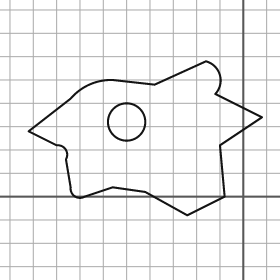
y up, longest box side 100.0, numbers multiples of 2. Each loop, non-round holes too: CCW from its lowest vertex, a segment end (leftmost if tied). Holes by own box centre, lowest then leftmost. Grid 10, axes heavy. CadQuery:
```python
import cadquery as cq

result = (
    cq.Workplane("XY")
    .moveTo(-24.0, -8.0)
    .lineTo(-8.0, 0.0)
    .lineTo(-10.0, 22.0)
    .lineTo(8.0, 34.0)
    .lineTo(-12.0, 44.0)
    .threePointArc((-10.0, 52.0), (-16.0, 58.0))
    .lineTo(-38.0, 48.0)
    .lineTo(-56.0, 50.0)
    .threePointArc((-66.0, 48.0), (-74.0, 42.0))
    .lineTo(-92.0, 28.0)
    .lineTo(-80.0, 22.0)
    .threePointArc((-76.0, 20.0), (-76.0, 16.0))
    .lineTo(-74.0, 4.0)
    .threePointArc((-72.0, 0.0), (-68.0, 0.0))
    .lineTo(-56.0, 4.0)
    .lineTo(-42.0, 2.0)
    .close()
    .moveTo(-50.0, 32.0)
    .circle(8.0)
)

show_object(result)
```